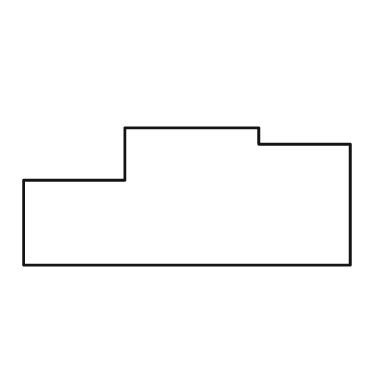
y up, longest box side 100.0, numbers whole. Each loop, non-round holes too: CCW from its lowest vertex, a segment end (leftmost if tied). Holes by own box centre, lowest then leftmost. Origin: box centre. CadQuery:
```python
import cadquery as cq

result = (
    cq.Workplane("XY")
    .moveTo(-50.0, -21.0)
    .lineTo(50.0, -21.0)
    .lineTo(50.0, 16.0)
    .lineTo(22.0, 16.0)
    .lineTo(22.0, 21.0)
    .lineTo(-19.0, 21.0)
    .lineTo(-19.0, 5.0)
    .lineTo(-50.0, 5.0)
    .close()
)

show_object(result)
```